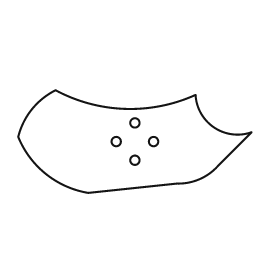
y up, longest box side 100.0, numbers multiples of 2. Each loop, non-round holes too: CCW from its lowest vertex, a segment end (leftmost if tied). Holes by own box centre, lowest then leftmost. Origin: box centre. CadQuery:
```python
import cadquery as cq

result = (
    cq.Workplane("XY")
    .moveTo(-20.0, -22.0)
    .lineTo(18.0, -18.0)
    .threePointArc((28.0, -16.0), (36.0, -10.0))
    .lineTo(50.0, 4.0)
    .threePointArc((34.0, 6.0), (26.0, 20.0))
    .threePointArc((-4.0, 14.0), (-34.0, 22.0))
    .threePointArc((-44.0, 14.0), (-50.0, 2.0))
    .threePointArc((-38.0, -14.0), (-20.0, -22.0))
    .close()
    .moveTo(0.0, -8.0)
    .circle(2.0)
    .moveTo(-8.0, 0.0)
    .circle(2.0)
    .moveTo(8.0, 0.0)
    .circle(2.0)
    .moveTo(0.0, 8.0)
    .circle(2.0)
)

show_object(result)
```